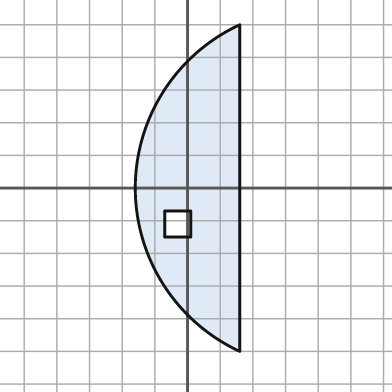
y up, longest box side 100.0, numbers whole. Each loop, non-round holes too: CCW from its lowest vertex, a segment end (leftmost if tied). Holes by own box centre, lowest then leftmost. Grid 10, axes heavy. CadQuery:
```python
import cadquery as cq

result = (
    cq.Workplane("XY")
    .moveTo(16.0, -50.0)
    .lineTo(16.0, 50.0)
    .threePointArc((-16.0, 0.0), (16.0, -50.0))
    .close()
    .moveTo(-7.0, -15.0)
    .lineTo(1.0, -15.0)
    .lineTo(1.0, -7.0)
    .lineTo(-7.0, -7.0)
    .close()
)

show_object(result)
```